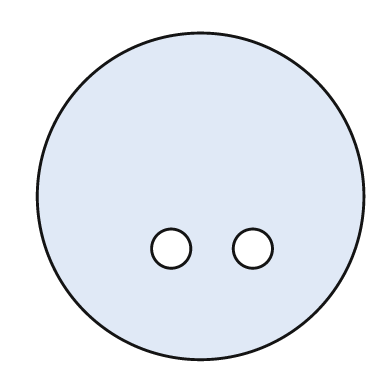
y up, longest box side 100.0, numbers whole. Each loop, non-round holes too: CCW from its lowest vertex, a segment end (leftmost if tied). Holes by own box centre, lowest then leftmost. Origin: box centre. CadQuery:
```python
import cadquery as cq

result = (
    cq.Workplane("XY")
    .moveTo(0.0, 0.0)
    .circle(50.0)
    .moveTo(-9.0, -16.0)
    .circle(6.0)
    .moveTo(16.0, -16.0)
    .circle(6.0)
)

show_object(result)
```